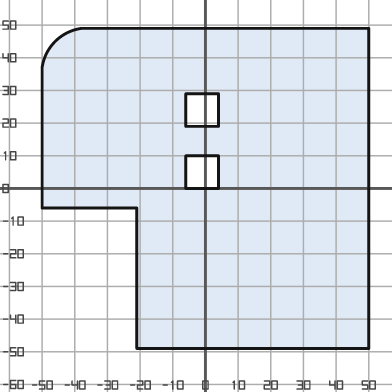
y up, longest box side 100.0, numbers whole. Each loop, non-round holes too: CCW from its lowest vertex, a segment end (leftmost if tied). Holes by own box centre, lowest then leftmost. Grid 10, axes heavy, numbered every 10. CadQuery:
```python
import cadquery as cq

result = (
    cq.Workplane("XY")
    .moveTo(-21.0, -49.0)
    .lineTo(50.0, -49.0)
    .lineTo(50.0, 49.0)
    .lineTo(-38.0, 49.0)
    .threePointArc((-46.0, 45.0), (-50.0, 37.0))
    .lineTo(-50.0, -6.0)
    .lineTo(-21.0, -6.0)
    .close()
    .moveTo(-6.0, 0.0)
    .lineTo(4.0, 0.0)
    .lineTo(4.0, 10.0)
    .lineTo(-6.0, 10.0)
    .close()
    .moveTo(-6.0, 19.0)
    .lineTo(4.0, 19.0)
    .lineTo(4.0, 29.0)
    .lineTo(-6.0, 29.0)
    .close()
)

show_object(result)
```